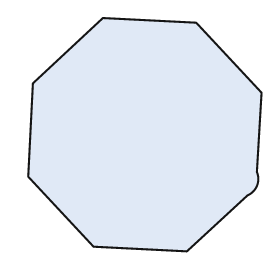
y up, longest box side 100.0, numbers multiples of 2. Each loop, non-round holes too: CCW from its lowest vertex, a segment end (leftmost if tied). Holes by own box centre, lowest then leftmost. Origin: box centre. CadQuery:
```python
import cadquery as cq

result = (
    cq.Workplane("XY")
    .moveTo(18.0, -50.0)
    .lineTo(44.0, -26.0)
    .threePointArc((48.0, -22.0), (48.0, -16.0))
    .lineTo(50.0, 18.0)
    .lineTo(22.0, 48.0)
    .lineTo(-18.0, 50.0)
    .lineTo(-48.0, 22.0)
    .lineTo(-50.0, -18.0)
    .lineTo(-22.0, -48.0)
    .close()
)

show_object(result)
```